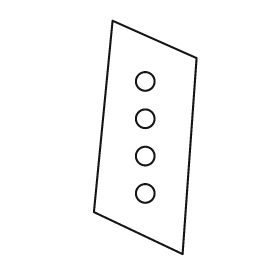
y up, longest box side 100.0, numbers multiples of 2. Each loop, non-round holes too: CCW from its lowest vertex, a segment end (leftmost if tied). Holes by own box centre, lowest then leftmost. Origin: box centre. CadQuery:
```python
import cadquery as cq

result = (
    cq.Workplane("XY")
    .moveTo(16.0, -50.0)
    .lineTo(22.0, 34.0)
    .lineTo(-14.0, 50.0)
    .lineTo(-22.0, -32.0)
    .close()
    .moveTo(0.0, -24.0)
    .circle(4.0)
    .moveTo(0.0, -8.0)
    .circle(4.0)
    .moveTo(0.0, 8.0)
    .circle(4.0)
    .moveTo(0.0, 24.0)
    .circle(4.0)
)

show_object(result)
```